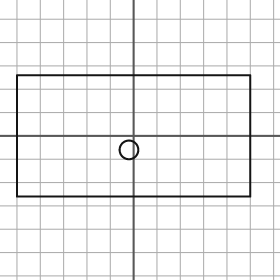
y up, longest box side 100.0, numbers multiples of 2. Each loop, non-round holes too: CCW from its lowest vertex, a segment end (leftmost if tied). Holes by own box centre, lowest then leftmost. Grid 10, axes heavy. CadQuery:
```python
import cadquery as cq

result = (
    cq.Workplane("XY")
    .moveTo(-50.0, -26.0)
    .lineTo(50.0, -26.0)
    .lineTo(50.0, 26.0)
    .lineTo(-50.0, 26.0)
    .close()
    .moveTo(-2.0, -6.0)
    .circle(4.0)
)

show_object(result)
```